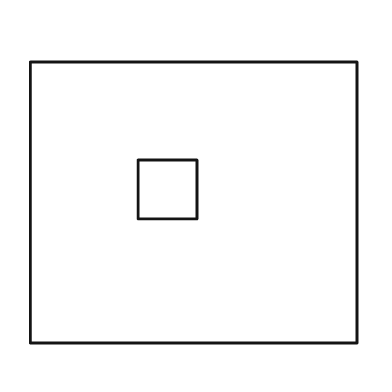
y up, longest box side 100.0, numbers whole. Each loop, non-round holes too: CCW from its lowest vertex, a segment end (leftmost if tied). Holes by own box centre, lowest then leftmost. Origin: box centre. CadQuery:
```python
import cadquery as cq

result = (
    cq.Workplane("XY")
    .moveTo(-50.0, -43.0)
    .lineTo(50.0, -43.0)
    .lineTo(50.0, 43.0)
    .lineTo(-50.0, 43.0)
    .close()
    .moveTo(-17.0, -5.0)
    .lineTo(1.0, -5.0)
    .lineTo(1.0, 13.0)
    .lineTo(-17.0, 13.0)
    .close()
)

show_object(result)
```